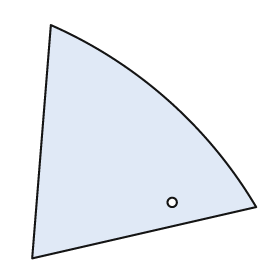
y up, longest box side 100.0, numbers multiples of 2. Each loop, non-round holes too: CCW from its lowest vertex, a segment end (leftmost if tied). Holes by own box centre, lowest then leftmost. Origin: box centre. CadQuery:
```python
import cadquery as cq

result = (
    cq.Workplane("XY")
    .moveTo(-48.0, -50.0)
    .lineTo(48.0, -28.0)
    .threePointArc((10.0, 18.0), (-40.0, 50.0))
    .close()
    .moveTo(12.0, -26.0)
    .circle(2.0)
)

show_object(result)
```